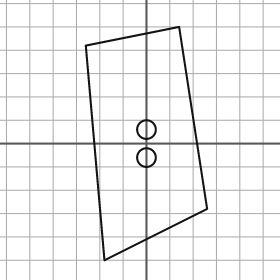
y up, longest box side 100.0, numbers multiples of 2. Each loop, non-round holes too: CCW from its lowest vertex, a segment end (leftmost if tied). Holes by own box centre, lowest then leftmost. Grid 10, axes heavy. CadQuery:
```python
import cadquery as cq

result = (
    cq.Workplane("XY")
    .moveTo(-18.0, -50.0)
    .lineTo(26.0, -28.0)
    .lineTo(14.0, 50.0)
    .lineTo(-26.0, 42.0)
    .close()
    .moveTo(0.0, -6.0)
    .circle(4.0)
    .moveTo(0.0, 6.0)
    .circle(4.0)
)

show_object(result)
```